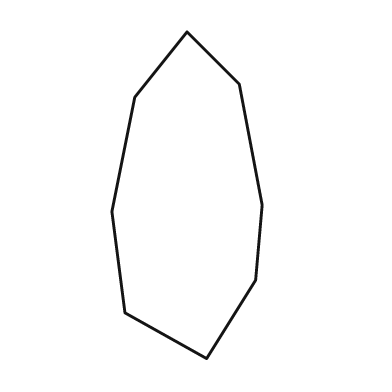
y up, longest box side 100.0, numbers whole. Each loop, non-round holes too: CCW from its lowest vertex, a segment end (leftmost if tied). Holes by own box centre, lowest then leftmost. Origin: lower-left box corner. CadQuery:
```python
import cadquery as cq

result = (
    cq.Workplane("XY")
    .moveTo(29.0, 0.0)
    .lineTo(44.0, 24.0)
    .lineTo(46.0, 47.0)
    .lineTo(39.0, 84.0)
    .lineTo(23.0, 100.0)
    .lineTo(7.0, 80.0)
    .lineTo(0.0, 45.0)
    .lineTo(4.0, 14.0)
    .close()
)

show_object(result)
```